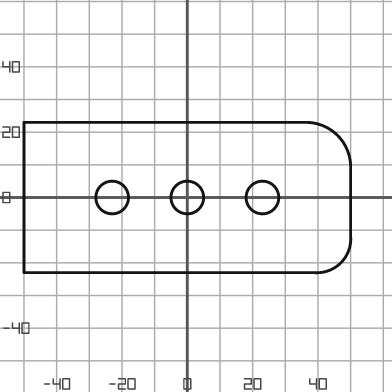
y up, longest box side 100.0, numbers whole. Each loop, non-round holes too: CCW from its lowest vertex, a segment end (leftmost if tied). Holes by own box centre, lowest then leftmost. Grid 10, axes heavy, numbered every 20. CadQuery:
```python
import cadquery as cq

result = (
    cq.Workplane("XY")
    .moveTo(-50.0, -23.0)
    .lineTo(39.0, -23.0)
    .threePointArc((47.0, -20.0), (50.0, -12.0))
    .lineTo(50.0, 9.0)
    .threePointArc((46.0, 19.0), (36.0, 23.0))
    .lineTo(-50.0, 23.0)
    .close()
    .moveTo(-23.0, 0.0)
    .circle(5.0)
    .moveTo(0.0, 0.0)
    .circle(5.0)
    .moveTo(23.0, 0.0)
    .circle(5.0)
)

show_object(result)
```